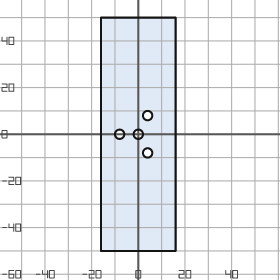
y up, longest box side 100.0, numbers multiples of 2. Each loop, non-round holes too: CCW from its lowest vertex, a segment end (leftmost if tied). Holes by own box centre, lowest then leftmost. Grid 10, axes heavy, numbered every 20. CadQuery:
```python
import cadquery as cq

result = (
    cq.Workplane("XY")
    .moveTo(-16.0, -50.0)
    .lineTo(16.0, -50.0)
    .lineTo(16.0, 50.0)
    .lineTo(-16.0, 50.0)
    .close()
    .moveTo(4.0, -8.0)
    .circle(2.0)
    .moveTo(-8.0, 0.0)
    .circle(2.0)
    .moveTo(0.0, 0.0)
    .circle(2.0)
    .moveTo(4.0, 8.0)
    .circle(2.0)
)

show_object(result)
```